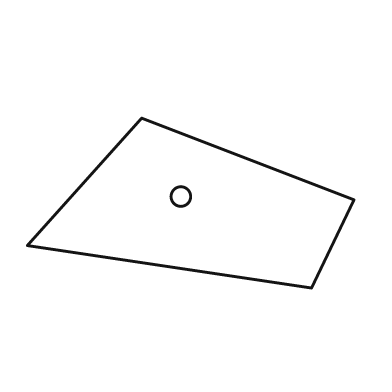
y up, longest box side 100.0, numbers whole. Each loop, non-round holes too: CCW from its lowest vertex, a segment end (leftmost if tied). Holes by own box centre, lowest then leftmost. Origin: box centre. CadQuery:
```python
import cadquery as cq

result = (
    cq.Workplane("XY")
    .moveTo(37.0, -26.0)
    .lineTo(50.0, 1.0)
    .lineTo(-15.0, 26.0)
    .lineTo(-50.0, -13.0)
    .close()
    .moveTo(-3.0, 2.0)
    .circle(3.0)
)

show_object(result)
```